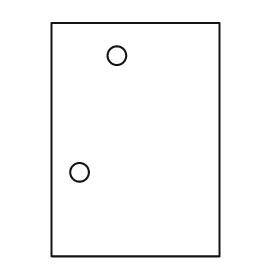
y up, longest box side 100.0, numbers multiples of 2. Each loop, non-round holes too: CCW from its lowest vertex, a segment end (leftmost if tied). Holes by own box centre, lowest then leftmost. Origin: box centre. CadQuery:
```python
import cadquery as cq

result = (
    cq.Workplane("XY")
    .moveTo(-36.0, -50.0)
    .lineTo(36.0, -50.0)
    .lineTo(36.0, 50.0)
    .lineTo(-36.0, 50.0)
    .close()
    .moveTo(-24.0, -14.0)
    .circle(4.0)
    .moveTo(-8.0, 36.0)
    .circle(4.0)
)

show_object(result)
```